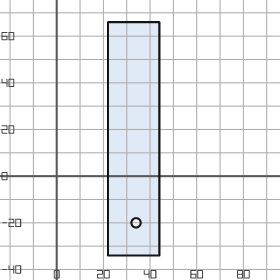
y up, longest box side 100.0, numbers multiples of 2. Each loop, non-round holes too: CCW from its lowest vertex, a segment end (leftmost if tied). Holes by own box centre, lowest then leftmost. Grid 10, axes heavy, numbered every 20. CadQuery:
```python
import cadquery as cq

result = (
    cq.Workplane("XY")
    .moveTo(22.0, -34.0)
    .lineTo(44.0, -34.0)
    .lineTo(44.0, 66.0)
    .lineTo(22.0, 66.0)
    .close()
    .moveTo(34.0, -20.0)
    .circle(2.0)
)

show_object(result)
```